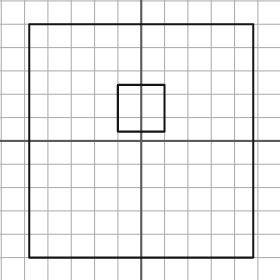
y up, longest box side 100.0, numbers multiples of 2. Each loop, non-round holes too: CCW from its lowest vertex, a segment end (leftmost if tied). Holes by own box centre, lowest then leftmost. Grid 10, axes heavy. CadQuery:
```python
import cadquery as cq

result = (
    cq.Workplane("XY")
    .moveTo(-48.0, -50.0)
    .lineTo(48.0, -50.0)
    .lineTo(48.0, 50.0)
    .lineTo(-48.0, 50.0)
    .close()
    .moveTo(-10.0, 4.0)
    .lineTo(10.0, 4.0)
    .lineTo(10.0, 24.0)
    .lineTo(-10.0, 24.0)
    .close()
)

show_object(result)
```